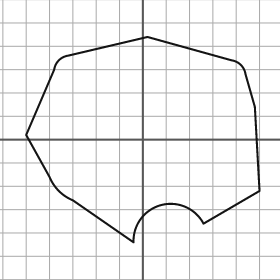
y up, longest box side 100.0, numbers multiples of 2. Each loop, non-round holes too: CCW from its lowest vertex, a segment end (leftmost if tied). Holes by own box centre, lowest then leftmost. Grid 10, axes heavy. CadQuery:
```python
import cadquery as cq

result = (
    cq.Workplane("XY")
    .moveTo(-4.0, -44.0)
    .threePointArc((8.0, -28.0), (26.0, -36.0))
    .lineTo(50.0, -22.0)
    .lineTo(48.0, 14.0)
    .lineTo(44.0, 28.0)
    .threePointArc((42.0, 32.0), (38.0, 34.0))
    .lineTo(2.0, 44.0)
    .lineTo(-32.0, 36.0)
    .threePointArc((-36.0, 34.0), (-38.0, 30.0))
    .lineTo(-50.0, 2.0)
    .lineTo(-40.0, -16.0)
    .threePointArc((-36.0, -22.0), (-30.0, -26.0))
    .close()
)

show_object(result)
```